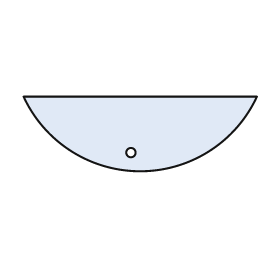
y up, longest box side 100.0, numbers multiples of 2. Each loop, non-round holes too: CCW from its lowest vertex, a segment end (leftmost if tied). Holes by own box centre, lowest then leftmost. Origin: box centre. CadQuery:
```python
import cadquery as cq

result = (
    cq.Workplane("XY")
    .moveTo(-50.0, 16.0)
    .threePointArc((0.0, -16.0), (50.0, 16.0))
    .close()
    .moveTo(-4.0, -8.0)
    .circle(2.0)
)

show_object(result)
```